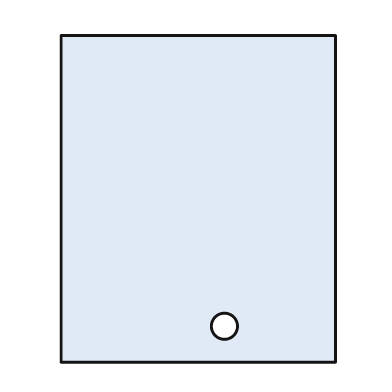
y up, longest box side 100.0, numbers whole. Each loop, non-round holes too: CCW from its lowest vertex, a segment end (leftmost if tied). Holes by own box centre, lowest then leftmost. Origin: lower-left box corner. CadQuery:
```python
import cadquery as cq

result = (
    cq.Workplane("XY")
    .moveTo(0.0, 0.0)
    .lineTo(84.0, 0.0)
    .lineTo(84.0, 100.0)
    .lineTo(0.0, 100.0)
    .close()
    .moveTo(50.0, 11.0)
    .circle(4.0)
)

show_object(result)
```